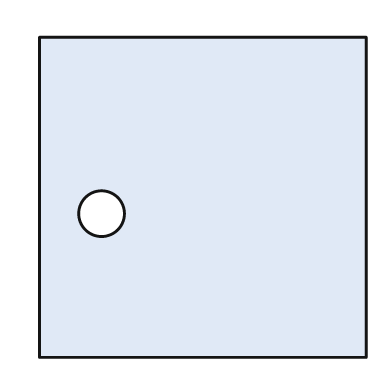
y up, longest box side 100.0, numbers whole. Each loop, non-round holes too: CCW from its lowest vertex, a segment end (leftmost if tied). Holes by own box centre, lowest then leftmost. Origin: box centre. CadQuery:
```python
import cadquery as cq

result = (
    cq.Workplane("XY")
    .moveTo(-50.0, -49.0)
    .lineTo(50.0, -49.0)
    .lineTo(50.0, 49.0)
    .lineTo(-50.0, 49.0)
    .close()
    .moveTo(-31.0, -5.0)
    .circle(7.0)
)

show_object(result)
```